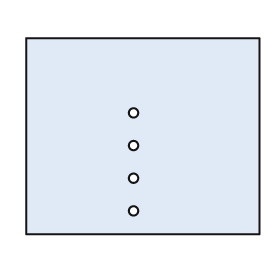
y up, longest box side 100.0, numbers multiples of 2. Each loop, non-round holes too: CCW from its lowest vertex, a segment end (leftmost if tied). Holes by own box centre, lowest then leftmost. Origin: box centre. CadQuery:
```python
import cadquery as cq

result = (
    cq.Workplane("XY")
    .moveTo(-50.0, -42.0)
    .lineTo(50.0, -42.0)
    .lineTo(50.0, 42.0)
    .lineTo(-50.0, 42.0)
    .close()
    .moveTo(-4.0, -32.0)
    .circle(2.0)
    .moveTo(-4.0, -18.0)
    .circle(2.0)
    .moveTo(-4.0, -4.0)
    .circle(2.0)
    .moveTo(-4.0, 10.0)
    .circle(2.0)
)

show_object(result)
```